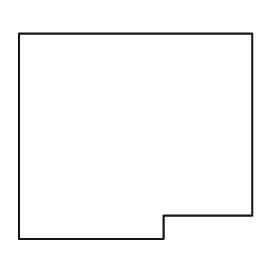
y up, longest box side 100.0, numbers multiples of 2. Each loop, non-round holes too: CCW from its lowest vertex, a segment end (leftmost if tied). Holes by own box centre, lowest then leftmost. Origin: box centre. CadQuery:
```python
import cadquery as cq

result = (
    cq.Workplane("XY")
    .moveTo(-50.0, -44.0)
    .lineTo(12.0, -44.0)
    .lineTo(12.0, -34.0)
    .lineTo(50.0, -34.0)
    .lineTo(50.0, 44.0)
    .lineTo(-50.0, 44.0)
    .close()
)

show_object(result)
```